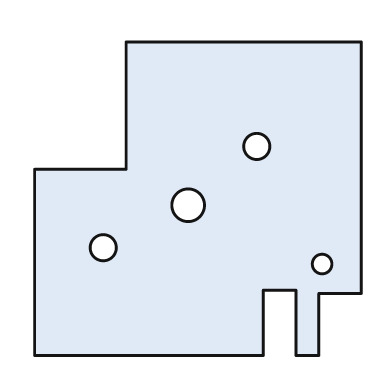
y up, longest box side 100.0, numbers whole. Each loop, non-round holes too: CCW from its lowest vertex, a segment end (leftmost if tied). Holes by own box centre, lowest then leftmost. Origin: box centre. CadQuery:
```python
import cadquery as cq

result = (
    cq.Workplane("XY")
    .moveTo(-50.0, -48.0)
    .lineTo(20.0, -48.0)
    .lineTo(20.0, -28.0)
    .lineTo(30.0, -28.0)
    .lineTo(30.0, -48.0)
    .lineTo(37.0, -48.0)
    .lineTo(37.0, -29.0)
    .lineTo(50.0, -29.0)
    .lineTo(50.0, 48.0)
    .lineTo(-22.0, 48.0)
    .lineTo(-22.0, 9.0)
    .lineTo(-50.0, 9.0)
    .close()
    .moveTo(38.0, -20.0)
    .circle(3.0)
    .moveTo(-29.0, -15.0)
    .circle(4.0)
    .moveTo(-3.0, -2.0)
    .circle(5.0)
    .moveTo(18.0, 16.0)
    .circle(4.0)
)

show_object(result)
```